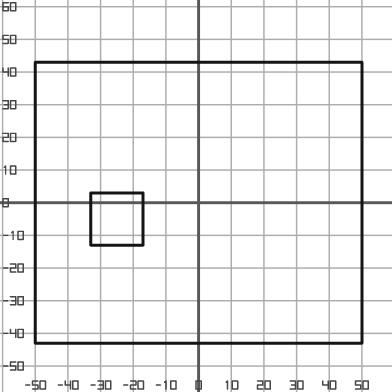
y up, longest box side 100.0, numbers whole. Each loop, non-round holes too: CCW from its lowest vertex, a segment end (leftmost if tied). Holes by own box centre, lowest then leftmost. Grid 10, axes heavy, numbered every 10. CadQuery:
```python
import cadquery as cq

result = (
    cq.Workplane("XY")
    .moveTo(-50.0, -43.0)
    .lineTo(50.0, -43.0)
    .lineTo(50.0, 43.0)
    .lineTo(-50.0, 43.0)
    .close()
    .moveTo(-33.0, -13.0)
    .lineTo(-17.0, -13.0)
    .lineTo(-17.0, 3.0)
    .lineTo(-33.0, 3.0)
    .close()
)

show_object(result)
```